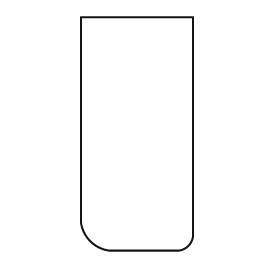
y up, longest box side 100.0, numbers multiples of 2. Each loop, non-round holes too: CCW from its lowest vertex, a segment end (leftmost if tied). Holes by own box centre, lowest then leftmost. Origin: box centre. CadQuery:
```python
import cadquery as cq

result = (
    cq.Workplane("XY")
    .moveTo(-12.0, -50.0)
    .lineTo(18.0, -50.0)
    .threePointArc((22.0, -48.0), (24.0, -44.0))
    .lineTo(24.0, 50.0)
    .lineTo(-24.0, 50.0)
    .lineTo(-24.0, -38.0)
    .threePointArc((-20.0, -46.0), (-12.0, -50.0))
    .close()
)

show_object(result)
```